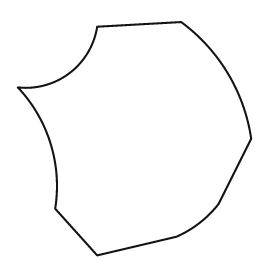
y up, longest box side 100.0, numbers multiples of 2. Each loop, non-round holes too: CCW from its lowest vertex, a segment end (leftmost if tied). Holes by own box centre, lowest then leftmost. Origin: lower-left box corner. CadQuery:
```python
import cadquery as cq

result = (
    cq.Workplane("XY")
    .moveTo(34.0, 0.0)
    .lineTo(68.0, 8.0)
    .threePointArc((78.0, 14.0), (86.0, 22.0))
    .lineTo(100.0, 50.0)
    .threePointArc((90.0, 78.0), (70.0, 100.0))
    .lineTo(34.0, 98.0)
    .threePointArc((22.0, 78.0), (0.0, 72.0))
    .threePointArc((14.0, 48.0), (16.0, 20.0))
    .close()
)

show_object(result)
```